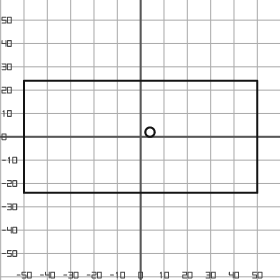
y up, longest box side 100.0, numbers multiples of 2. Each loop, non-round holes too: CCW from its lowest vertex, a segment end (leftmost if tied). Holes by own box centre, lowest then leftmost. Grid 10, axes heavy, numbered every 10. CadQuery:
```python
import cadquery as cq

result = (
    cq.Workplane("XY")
    .moveTo(-50.0, -24.0)
    .lineTo(50.0, -24.0)
    .lineTo(50.0, 24.0)
    .lineTo(-50.0, 24.0)
    .close()
    .moveTo(4.0, 2.0)
    .circle(2.0)
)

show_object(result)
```